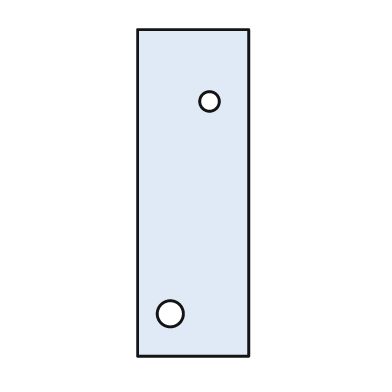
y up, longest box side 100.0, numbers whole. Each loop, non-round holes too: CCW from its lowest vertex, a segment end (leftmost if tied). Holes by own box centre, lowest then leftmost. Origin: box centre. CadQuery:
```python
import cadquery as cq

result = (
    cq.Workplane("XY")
    .moveTo(-17.0, -50.0)
    .lineTo(17.0, -50.0)
    .lineTo(17.0, 50.0)
    .lineTo(-17.0, 50.0)
    .close()
    .moveTo(-7.0, -37.0)
    .circle(4.0)
    .moveTo(5.0, 28.0)
    .circle(3.0)
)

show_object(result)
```